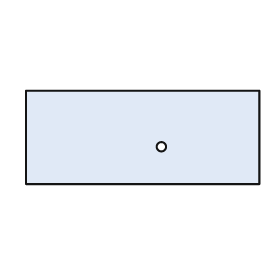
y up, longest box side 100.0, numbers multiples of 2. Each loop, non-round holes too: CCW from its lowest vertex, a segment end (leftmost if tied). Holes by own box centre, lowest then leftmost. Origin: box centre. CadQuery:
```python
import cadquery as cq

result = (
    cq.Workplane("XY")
    .moveTo(-50.0, -20.0)
    .lineTo(50.0, -20.0)
    .lineTo(50.0, 20.0)
    .lineTo(-50.0, 20.0)
    .close()
    .moveTo(8.0, -4.0)
    .circle(2.0)
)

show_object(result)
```